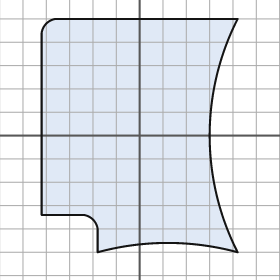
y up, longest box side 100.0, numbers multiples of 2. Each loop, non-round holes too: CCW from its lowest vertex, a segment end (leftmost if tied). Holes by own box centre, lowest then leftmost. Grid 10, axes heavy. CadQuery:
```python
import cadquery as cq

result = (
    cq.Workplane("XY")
    .moveTo(-18.0, -50.0)
    .threePointArc((12.0, -46.0), (42.0, -50.0))
    .threePointArc((30.0, 0.0), (42.0, 50.0))
    .lineTo(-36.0, 50.0)
    .threePointArc((-40.0, 48.0), (-42.0, 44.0))
    .lineTo(-42.0, -34.0)
    .lineTo(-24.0, -34.0)
    .threePointArc((-20.0, -36.0), (-18.0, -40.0))
    .close()
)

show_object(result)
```